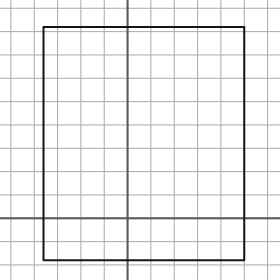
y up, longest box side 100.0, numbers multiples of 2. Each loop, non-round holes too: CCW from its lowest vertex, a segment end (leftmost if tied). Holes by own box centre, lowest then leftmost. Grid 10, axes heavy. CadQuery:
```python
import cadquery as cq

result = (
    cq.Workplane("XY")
    .moveTo(-36.0, -18.0)
    .lineTo(50.0, -18.0)
    .lineTo(50.0, 82.0)
    .lineTo(-36.0, 82.0)
    .close()
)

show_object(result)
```